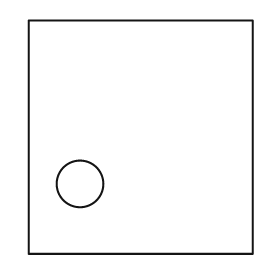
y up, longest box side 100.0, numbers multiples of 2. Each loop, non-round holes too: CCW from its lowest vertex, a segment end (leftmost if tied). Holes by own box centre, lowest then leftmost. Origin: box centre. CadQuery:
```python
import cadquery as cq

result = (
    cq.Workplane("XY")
    .moveTo(-48.0, -50.0)
    .lineTo(48.0, -50.0)
    .lineTo(48.0, 50.0)
    .lineTo(-48.0, 50.0)
    .close()
    .moveTo(-26.0, -20.0)
    .circle(10.0)
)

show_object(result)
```